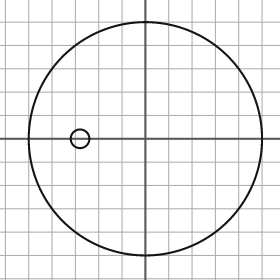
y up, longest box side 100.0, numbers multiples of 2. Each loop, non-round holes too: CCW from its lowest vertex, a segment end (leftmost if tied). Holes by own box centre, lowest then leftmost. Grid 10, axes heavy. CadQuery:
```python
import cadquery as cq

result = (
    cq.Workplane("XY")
    .moveTo(0.0, 0.0)
    .circle(50.0)
    .moveTo(-28.0, 0.0)
    .circle(4.0)
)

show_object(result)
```